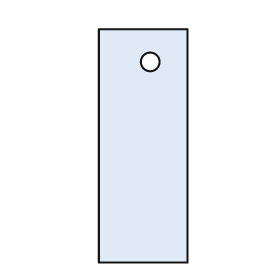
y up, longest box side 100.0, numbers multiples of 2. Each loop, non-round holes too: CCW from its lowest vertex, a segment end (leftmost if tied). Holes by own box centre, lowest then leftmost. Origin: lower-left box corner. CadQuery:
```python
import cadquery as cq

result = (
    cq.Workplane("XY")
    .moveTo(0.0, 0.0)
    .lineTo(38.0, 0.0)
    .lineTo(38.0, 100.0)
    .lineTo(0.0, 100.0)
    .close()
    .moveTo(22.0, 86.0)
    .circle(4.0)
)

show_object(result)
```